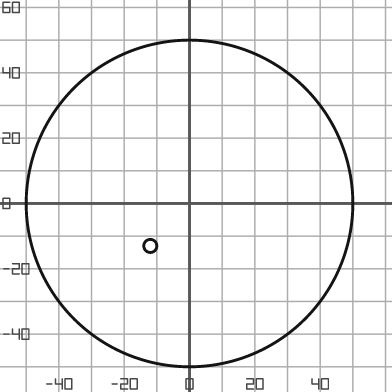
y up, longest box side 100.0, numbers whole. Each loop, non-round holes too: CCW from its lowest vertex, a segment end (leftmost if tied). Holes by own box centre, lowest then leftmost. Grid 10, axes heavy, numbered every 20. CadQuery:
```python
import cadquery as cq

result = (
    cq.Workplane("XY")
    .moveTo(0.0, 0.0)
    .circle(50.0)
    .moveTo(-12.0, -13.0)
    .circle(2.0)
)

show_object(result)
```